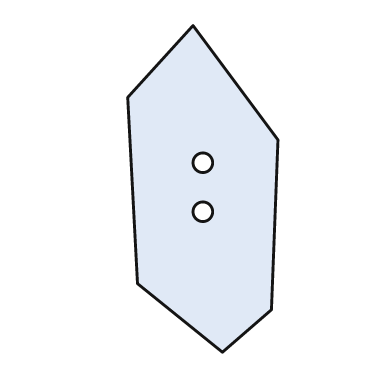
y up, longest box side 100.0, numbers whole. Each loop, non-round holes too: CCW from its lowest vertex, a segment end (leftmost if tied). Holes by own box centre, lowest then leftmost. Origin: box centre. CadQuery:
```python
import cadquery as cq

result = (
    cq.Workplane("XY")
    .moveTo(6.0, -50.0)
    .lineTo(21.0, -37.0)
    .lineTo(23.0, 15.0)
    .lineTo(-3.0, 50.0)
    .lineTo(-23.0, 28.0)
    .lineTo(-20.0, -29.0)
    .close()
    .moveTo(0.0, -7.0)
    .circle(3.0)
    .moveTo(0.0, 8.0)
    .circle(3.0)
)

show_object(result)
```